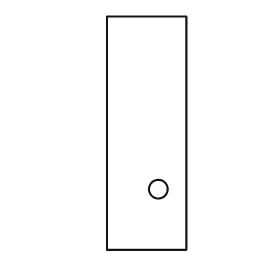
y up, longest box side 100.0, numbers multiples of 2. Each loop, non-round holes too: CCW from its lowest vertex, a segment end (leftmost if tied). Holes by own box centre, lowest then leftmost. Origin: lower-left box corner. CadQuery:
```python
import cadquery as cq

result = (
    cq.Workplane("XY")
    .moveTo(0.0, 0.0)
    .lineTo(34.0, 0.0)
    .lineTo(34.0, 100.0)
    .lineTo(0.0, 100.0)
    .close()
    .moveTo(22.0, 26.0)
    .circle(4.0)
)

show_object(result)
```